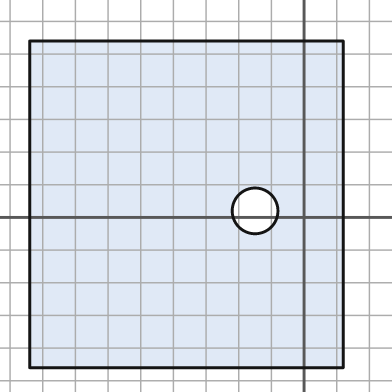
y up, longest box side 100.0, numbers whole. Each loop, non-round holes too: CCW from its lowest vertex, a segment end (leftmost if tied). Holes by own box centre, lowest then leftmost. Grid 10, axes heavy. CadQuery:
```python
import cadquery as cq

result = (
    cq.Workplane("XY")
    .moveTo(-84.0, -46.0)
    .lineTo(12.0, -46.0)
    .lineTo(12.0, 54.0)
    .lineTo(-84.0, 54.0)
    .close()
    .moveTo(-15.0, 2.0)
    .circle(7.0)
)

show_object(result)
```